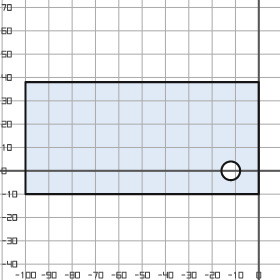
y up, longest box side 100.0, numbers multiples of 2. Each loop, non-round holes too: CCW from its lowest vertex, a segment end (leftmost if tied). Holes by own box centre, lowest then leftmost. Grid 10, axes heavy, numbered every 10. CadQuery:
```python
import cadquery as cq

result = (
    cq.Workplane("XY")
    .moveTo(-100.0, -10.0)
    .lineTo(0.0, -10.0)
    .lineTo(0.0, 38.0)
    .lineTo(-100.0, 38.0)
    .close()
    .moveTo(-12.0, 0.0)
    .circle(4.0)
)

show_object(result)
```